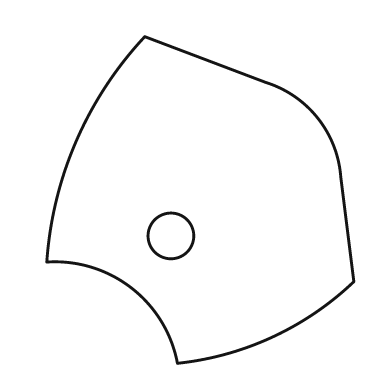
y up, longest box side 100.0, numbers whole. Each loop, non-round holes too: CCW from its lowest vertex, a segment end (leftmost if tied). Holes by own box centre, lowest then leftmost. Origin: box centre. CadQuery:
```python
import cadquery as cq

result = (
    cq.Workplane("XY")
    .moveTo(-7.0, -50.0)
    .threePointArc((22.0, -42.0), (47.0, -25.0))
    .lineTo(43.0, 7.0)
    .threePointArc((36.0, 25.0), (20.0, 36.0))
    .lineTo(-17.0, 50.0)
    .threePointArc((-38.0, 18.0), (-47.0, -19.0))
    .threePointArc((-21.0, -27.0), (-7.0, -50.0))
    .close()
    .moveTo(-9.0, -11.0)
    .circle(7.0)
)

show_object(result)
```